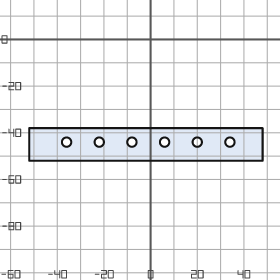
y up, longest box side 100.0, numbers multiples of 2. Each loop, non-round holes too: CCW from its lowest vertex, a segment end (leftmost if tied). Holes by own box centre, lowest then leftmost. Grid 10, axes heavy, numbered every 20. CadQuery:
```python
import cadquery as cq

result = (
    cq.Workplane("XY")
    .moveTo(-52.0, -52.0)
    .lineTo(48.0, -52.0)
    .lineTo(48.0, -38.0)
    .lineTo(-52.0, -38.0)
    .close()
    .moveTo(-36.0, -44.0)
    .circle(2.0)
    .moveTo(-22.0, -44.0)
    .circle(2.0)
    .moveTo(-8.0, -44.0)
    .circle(2.0)
    .moveTo(6.0, -44.0)
    .circle(2.0)
    .moveTo(20.0, -44.0)
    .circle(2.0)
    .moveTo(34.0, -44.0)
    .circle(2.0)
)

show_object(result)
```